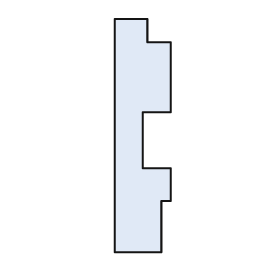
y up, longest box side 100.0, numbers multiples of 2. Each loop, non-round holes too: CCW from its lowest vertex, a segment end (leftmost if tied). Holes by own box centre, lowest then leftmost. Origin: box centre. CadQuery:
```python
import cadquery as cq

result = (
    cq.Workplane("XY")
    .moveTo(-12.0, -50.0)
    .lineTo(8.0, -50.0)
    .lineTo(8.0, -28.0)
    .lineTo(12.0, -28.0)
    .lineTo(12.0, -14.0)
    .lineTo(0.0, -14.0)
    .lineTo(0.0, 10.0)
    .lineTo(12.0, 10.0)
    .lineTo(12.0, 40.0)
    .lineTo(2.0, 40.0)
    .lineTo(2.0, 50.0)
    .lineTo(-12.0, 50.0)
    .close()
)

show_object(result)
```